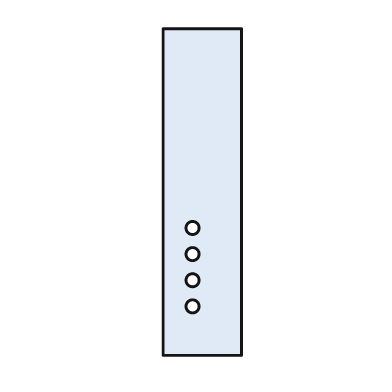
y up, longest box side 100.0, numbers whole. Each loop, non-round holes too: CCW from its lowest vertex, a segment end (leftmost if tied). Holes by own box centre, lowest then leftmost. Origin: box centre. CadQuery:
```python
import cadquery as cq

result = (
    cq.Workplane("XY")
    .moveTo(-12.0, -50.0)
    .lineTo(12.0, -50.0)
    .lineTo(12.0, 50.0)
    .lineTo(-12.0, 50.0)
    .close()
    .moveTo(-3.0, -35.0)
    .circle(2.0)
    .moveTo(-3.0, -27.0)
    .circle(2.0)
    .moveTo(-3.0, -19.0)
    .circle(2.0)
    .moveTo(-3.0, -11.0)
    .circle(2.0)
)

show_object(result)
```